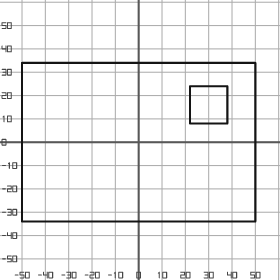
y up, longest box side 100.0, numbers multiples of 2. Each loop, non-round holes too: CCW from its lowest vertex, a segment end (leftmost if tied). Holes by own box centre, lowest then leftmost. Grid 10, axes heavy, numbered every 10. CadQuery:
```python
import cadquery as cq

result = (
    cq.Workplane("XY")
    .moveTo(-50.0, -34.0)
    .lineTo(50.0, -34.0)
    .lineTo(50.0, 34.0)
    .lineTo(-50.0, 34.0)
    .close()
    .moveTo(22.0, 8.0)
    .lineTo(38.0, 8.0)
    .lineTo(38.0, 24.0)
    .lineTo(22.0, 24.0)
    .close()
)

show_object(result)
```